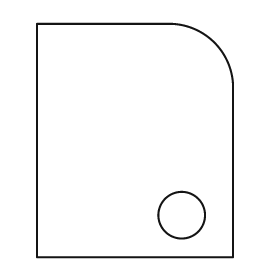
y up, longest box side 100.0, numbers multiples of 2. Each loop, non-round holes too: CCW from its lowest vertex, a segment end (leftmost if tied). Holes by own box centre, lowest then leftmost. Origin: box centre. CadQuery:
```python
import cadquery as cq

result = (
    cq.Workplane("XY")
    .moveTo(-42.0, -50.0)
    .lineTo(42.0, -50.0)
    .lineTo(42.0, 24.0)
    .threePointArc((34.0, 42.0), (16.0, 50.0))
    .lineTo(-42.0, 50.0)
    .close()
    .moveTo(20.0, -32.0)
    .circle(10.0)
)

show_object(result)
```